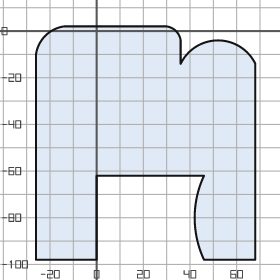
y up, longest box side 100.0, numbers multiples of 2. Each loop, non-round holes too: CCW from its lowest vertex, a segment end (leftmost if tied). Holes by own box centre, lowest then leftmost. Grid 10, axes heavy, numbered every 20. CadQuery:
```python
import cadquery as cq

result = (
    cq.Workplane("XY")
    .moveTo(-26.0, -98.0)
    .lineTo(0.0, -98.0)
    .lineTo(0.0, -62.0)
    .lineTo(46.0, -62.0)
    .threePointArc((42.0, -80.0), (46.0, -98.0))
    .lineTo(68.0, -98.0)
    .lineTo(68.0, -14.0)
    .threePointArc((52.0, -4.0), (36.0, -14.0))
    .lineTo(36.0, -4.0)
    .threePointArc((34.0, 0.0), (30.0, 2.0))
    .lineTo(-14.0, 2.0)
    .threePointArc((-22.0, -2.0), (-26.0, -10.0))
    .close()
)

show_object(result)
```